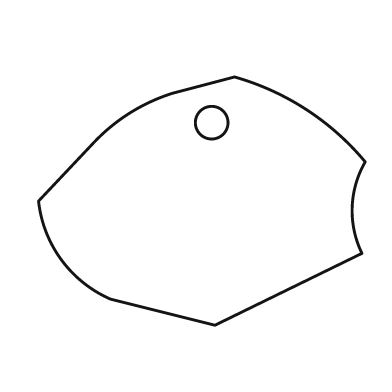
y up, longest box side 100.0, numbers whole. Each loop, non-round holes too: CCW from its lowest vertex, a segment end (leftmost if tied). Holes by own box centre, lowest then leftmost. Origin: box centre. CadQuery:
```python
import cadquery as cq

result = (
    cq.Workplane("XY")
    .moveTo(4.0, -38.0)
    .lineTo(49.0, -16.0)
    .threePointArc((46.0, -2.0), (50.0, 12.0))
    .threePointArc((32.0, 28.0), (10.0, 38.0))
    .lineTo(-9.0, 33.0)
    .threePointArc((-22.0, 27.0), (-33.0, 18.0))
    .lineTo(-50.0, 0.0)
    .threePointArc((-43.0, -18.0), (-28.0, -30.0))
    .close()
    .moveTo(3.0, 24.0)
    .circle(5.0)
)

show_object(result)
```